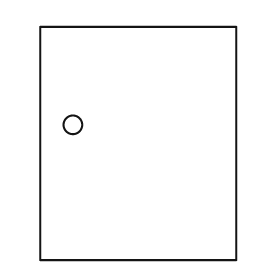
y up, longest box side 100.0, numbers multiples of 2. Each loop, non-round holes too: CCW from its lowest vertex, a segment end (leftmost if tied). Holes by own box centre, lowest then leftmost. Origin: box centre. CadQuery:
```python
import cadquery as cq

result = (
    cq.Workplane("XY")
    .moveTo(-42.0, -50.0)
    .lineTo(42.0, -50.0)
    .lineTo(42.0, 50.0)
    .lineTo(-42.0, 50.0)
    .close()
    .moveTo(-28.0, 8.0)
    .circle(4.0)
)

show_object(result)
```